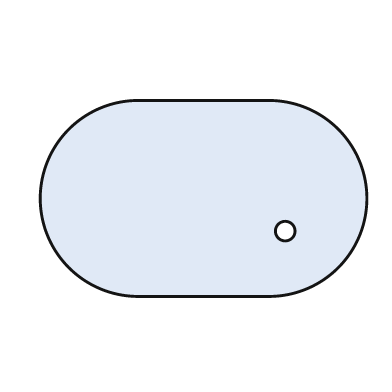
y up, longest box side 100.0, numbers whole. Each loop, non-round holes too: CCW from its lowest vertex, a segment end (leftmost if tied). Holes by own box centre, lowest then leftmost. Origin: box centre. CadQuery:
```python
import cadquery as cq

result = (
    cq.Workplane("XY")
    .moveTo(-20.0, -30.0)
    .lineTo(20.0, -30.0)
    .threePointArc((50.0, 0.0), (20.0, 30.0))
    .lineTo(-20.0, 30.0)
    .threePointArc((-50.0, 0.0), (-20.0, -30.0))
    .close()
    .moveTo(25.0, -10.0)
    .circle(3.0)
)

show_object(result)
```